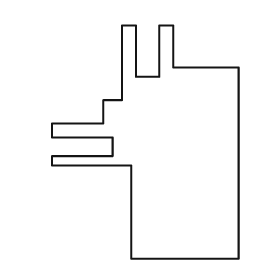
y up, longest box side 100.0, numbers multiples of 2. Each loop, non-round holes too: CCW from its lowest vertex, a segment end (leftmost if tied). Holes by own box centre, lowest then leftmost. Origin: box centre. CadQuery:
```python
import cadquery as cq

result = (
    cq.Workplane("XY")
    .moveTo(-6.0, -50.0)
    .lineTo(40.0, -50.0)
    .lineTo(40.0, 32.0)
    .lineTo(12.0, 32.0)
    .lineTo(12.0, 50.0)
    .lineTo(6.0, 50.0)
    .lineTo(6.0, 28.0)
    .lineTo(-4.0, 28.0)
    .lineTo(-4.0, 50.0)
    .lineTo(-10.0, 50.0)
    .lineTo(-10.0, 18.0)
    .lineTo(-18.0, 18.0)
    .lineTo(-18.0, 8.0)
    .lineTo(-40.0, 8.0)
    .lineTo(-40.0, 2.0)
    .lineTo(-14.0, 2.0)
    .lineTo(-14.0, -6.0)
    .lineTo(-40.0, -6.0)
    .lineTo(-40.0, -10.0)
    .lineTo(-6.0, -10.0)
    .close()
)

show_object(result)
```